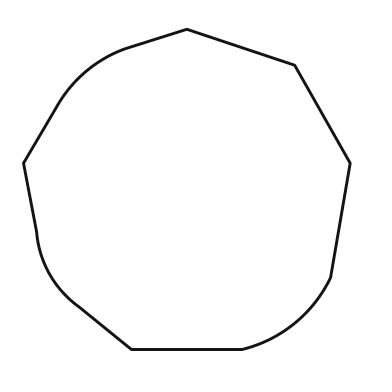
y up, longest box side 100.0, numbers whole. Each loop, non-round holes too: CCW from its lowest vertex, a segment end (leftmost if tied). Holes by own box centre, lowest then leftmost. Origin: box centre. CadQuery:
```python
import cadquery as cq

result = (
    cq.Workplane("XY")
    .moveTo(-17.0, -49.0)
    .lineTo(17.0, -49.0)
    .threePointArc((33.0, -41.0), (44.0, -27.0))
    .lineTo(50.0, 8.0)
    .lineTo(33.0, 38.0)
    .lineTo(0.0, 49.0)
    .lineTo(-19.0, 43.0)
    .threePointArc((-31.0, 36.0), (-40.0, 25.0))
    .lineTo(-50.0, 8.0)
    .lineTo(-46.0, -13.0)
    .threePointArc((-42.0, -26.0), (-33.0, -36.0))
    .close()
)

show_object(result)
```